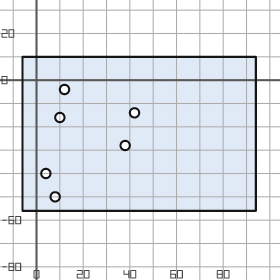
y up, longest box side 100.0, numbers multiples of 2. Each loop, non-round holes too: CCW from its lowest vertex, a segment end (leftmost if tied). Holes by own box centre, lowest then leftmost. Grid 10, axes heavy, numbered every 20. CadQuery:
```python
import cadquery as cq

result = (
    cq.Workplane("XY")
    .moveTo(-6.0, -56.0)
    .lineTo(94.0, -56.0)
    .lineTo(94.0, 10.0)
    .lineTo(-6.0, 10.0)
    .close()
    .moveTo(8.0, -50.0)
    .circle(2.0)
    .moveTo(4.0, -40.0)
    .circle(2.0)
    .moveTo(38.0, -28.0)
    .circle(2.0)
    .moveTo(10.0, -16.0)
    .circle(2.0)
    .moveTo(42.0, -14.0)
    .circle(2.0)
    .moveTo(12.0, -4.0)
    .circle(2.0)
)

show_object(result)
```